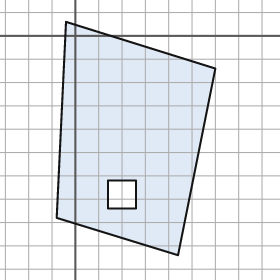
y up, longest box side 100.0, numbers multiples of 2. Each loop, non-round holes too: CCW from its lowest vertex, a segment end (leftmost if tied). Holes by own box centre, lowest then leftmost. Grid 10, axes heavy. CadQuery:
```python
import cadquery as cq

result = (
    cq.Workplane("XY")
    .moveTo(44.0, -94.0)
    .lineTo(60.0, -14.0)
    .lineTo(-4.0, 6.0)
    .lineTo(-8.0, -78.0)
    .close()
    .moveTo(14.0, -74.0)
    .lineTo(26.0, -74.0)
    .lineTo(26.0, -62.0)
    .lineTo(14.0, -62.0)
    .close()
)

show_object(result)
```